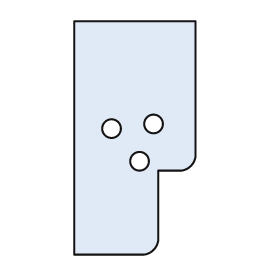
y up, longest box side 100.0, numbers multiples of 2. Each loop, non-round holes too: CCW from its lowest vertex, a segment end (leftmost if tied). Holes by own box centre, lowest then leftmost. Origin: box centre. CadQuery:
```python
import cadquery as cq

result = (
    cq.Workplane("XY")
    .moveTo(-26.0, -50.0)
    .lineTo(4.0, -50.0)
    .threePointArc((8.0, -48.0), (10.0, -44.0))
    .lineTo(10.0, -14.0)
    .lineTo(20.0, -14.0)
    .threePointArc((24.0, -12.0), (26.0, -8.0))
    .lineTo(26.0, 50.0)
    .lineTo(-26.0, 50.0)
    .close()
    .moveTo(2.0, -10.0)
    .circle(4.0)
    .moveTo(-10.0, 4.0)
    .circle(4.0)
    .moveTo(8.0, 6.0)
    .circle(4.0)
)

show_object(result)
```